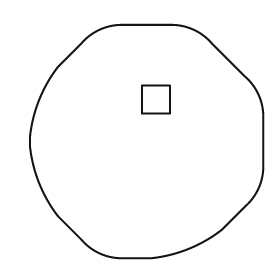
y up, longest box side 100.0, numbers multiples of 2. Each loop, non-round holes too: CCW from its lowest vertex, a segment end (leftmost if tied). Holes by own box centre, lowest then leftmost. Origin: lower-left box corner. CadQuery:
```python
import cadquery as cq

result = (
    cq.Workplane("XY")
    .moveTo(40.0, 0.0)
    .lineTo(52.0, 0.0)
    .threePointArc((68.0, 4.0), (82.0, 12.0))
    .lineTo(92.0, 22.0)
    .threePointArc((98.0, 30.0), (100.0, 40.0))
    .lineTo(100.0, 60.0)
    .threePointArc((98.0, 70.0), (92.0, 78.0))
    .lineTo(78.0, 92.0)
    .threePointArc((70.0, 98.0), (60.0, 100.0))
    .lineTo(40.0, 100.0)
    .threePointArc((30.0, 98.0), (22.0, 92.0))
    .lineTo(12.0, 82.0)
    .threePointArc((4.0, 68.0), (0.0, 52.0))
    .lineTo(0.0, 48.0)
    .threePointArc((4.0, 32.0), (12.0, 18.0))
    .lineTo(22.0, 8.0)
    .threePointArc((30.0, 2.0), (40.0, 0.0))
    .close()
    .moveTo(48.0, 62.0)
    .lineTo(60.0, 62.0)
    .lineTo(60.0, 74.0)
    .lineTo(48.0, 74.0)
    .close()
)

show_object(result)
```